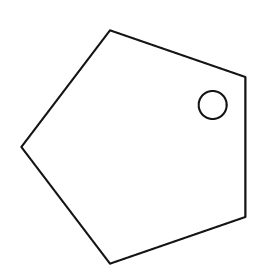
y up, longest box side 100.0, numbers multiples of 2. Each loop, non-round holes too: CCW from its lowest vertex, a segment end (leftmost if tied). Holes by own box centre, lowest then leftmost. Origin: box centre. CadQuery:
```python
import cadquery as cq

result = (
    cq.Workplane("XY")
    .moveTo(-10.0, -50.0)
    .lineTo(48.0, -30.0)
    .lineTo(48.0, 30.0)
    .lineTo(-10.0, 50.0)
    .lineTo(-48.0, 0.0)
    .close()
    .moveTo(34.0, 18.0)
    .circle(6.0)
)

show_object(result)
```